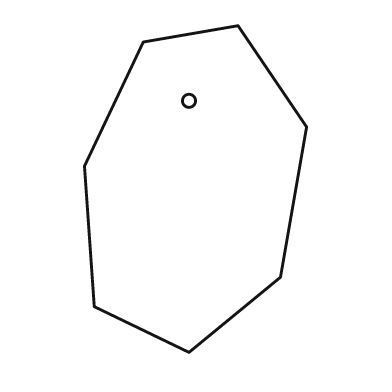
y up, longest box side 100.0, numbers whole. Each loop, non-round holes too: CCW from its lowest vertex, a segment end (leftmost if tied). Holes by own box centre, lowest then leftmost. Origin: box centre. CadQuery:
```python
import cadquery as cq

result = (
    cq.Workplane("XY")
    .moveTo(-2.0, -50.0)
    .lineTo(26.0, -27.0)
    .lineTo(34.0, 19.0)
    .lineTo(13.0, 50.0)
    .lineTo(-16.0, 45.0)
    .lineTo(-34.0, 7.0)
    .lineTo(-31.0, -36.0)
    .close()
    .moveTo(-2.0, 27.0)
    .circle(2.0)
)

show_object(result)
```